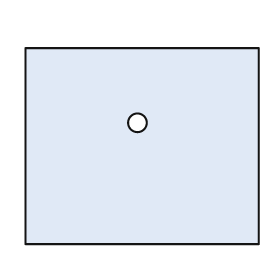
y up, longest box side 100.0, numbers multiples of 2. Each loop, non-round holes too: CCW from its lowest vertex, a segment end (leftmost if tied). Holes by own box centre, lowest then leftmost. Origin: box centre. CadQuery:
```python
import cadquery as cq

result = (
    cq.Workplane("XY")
    .moveTo(-50.0, -42.0)
    .lineTo(50.0, -42.0)
    .lineTo(50.0, 42.0)
    .lineTo(-50.0, 42.0)
    .close()
    .moveTo(-2.0, 10.0)
    .circle(4.0)
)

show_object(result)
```